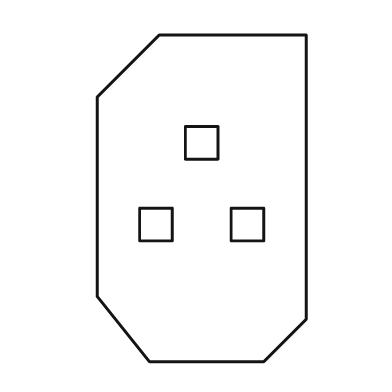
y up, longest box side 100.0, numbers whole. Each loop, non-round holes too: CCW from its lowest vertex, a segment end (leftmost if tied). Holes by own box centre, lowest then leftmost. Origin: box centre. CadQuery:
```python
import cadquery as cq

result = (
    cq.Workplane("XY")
    .moveTo(-16.0, -50.0)
    .lineTo(19.0, -50.0)
    .lineTo(32.0, -37.0)
    .lineTo(32.0, 50.0)
    .lineTo(-13.0, 50.0)
    .lineTo(-32.0, 31.0)
    .lineTo(-32.0, -30.0)
    .close()
    .moveTo(-19.0, -13.0)
    .lineTo(-9.0, -13.0)
    .lineTo(-9.0, -3.0)
    .lineTo(-19.0, -3.0)
    .close()
    .moveTo(9.0, -13.0)
    .lineTo(19.0, -13.0)
    .lineTo(19.0, -3.0)
    .lineTo(9.0, -3.0)
    .close()
    .moveTo(-5.0, 12.0)
    .lineTo(5.0, 12.0)
    .lineTo(5.0, 22.0)
    .lineTo(-5.0, 22.0)
    .close()
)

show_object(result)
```